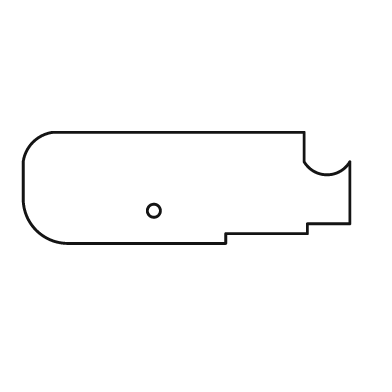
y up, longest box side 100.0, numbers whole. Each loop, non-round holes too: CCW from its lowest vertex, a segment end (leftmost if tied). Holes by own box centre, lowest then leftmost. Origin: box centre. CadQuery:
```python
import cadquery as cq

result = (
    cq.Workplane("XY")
    .moveTo(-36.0, -17.0)
    .lineTo(12.0, -17.0)
    .lineTo(12.0, -14.0)
    .lineTo(37.0, -14.0)
    .lineTo(37.0, -11.0)
    .lineTo(50.0, -11.0)
    .lineTo(50.0, 8.0)
    .threePointArc((43.0, 4.0), (36.0, 8.0))
    .lineTo(36.0, 17.0)
    .lineTo(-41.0, 17.0)
    .threePointArc((-47.0, 14.0), (-50.0, 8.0))
    .lineTo(-50.0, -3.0)
    .threePointArc((-46.0, -13.0), (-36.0, -17.0))
    .close()
    .moveTo(-10.0, -7.0)
    .circle(2.0)
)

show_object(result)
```